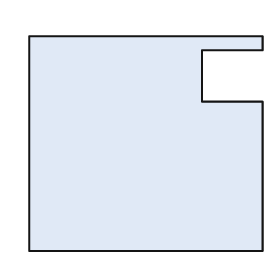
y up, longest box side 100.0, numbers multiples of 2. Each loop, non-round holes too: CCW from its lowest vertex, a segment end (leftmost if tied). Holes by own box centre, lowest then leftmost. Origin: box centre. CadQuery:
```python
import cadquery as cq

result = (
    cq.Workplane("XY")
    .moveTo(-50.0, -46.0)
    .lineTo(50.0, -46.0)
    .lineTo(50.0, 18.0)
    .lineTo(24.0, 18.0)
    .lineTo(24.0, 40.0)
    .lineTo(50.0, 40.0)
    .lineTo(50.0, 46.0)
    .lineTo(-50.0, 46.0)
    .close()
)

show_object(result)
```